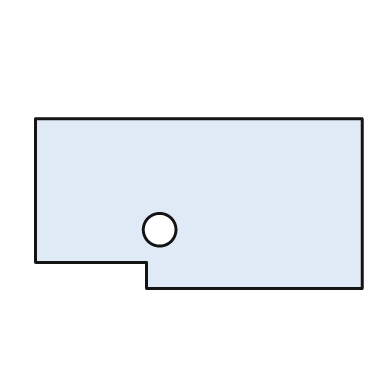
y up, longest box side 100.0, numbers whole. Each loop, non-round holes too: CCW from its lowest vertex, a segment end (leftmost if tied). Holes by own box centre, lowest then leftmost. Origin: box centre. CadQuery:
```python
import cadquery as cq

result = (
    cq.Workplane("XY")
    .moveTo(-16.0, -26.0)
    .lineTo(50.0, -26.0)
    .lineTo(50.0, 26.0)
    .lineTo(-50.0, 26.0)
    .lineTo(-50.0, -18.0)
    .lineTo(-16.0, -18.0)
    .close()
    .moveTo(-12.0, -8.0)
    .circle(5.0)
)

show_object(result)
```